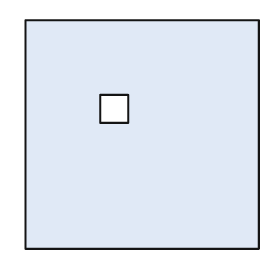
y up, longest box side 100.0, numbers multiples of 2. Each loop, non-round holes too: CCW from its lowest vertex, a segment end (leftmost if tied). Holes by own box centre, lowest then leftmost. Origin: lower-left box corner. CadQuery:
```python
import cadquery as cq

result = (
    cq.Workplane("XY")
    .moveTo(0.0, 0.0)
    .lineTo(100.0, 0.0)
    .lineTo(100.0, 98.0)
    .lineTo(0.0, 98.0)
    .close()
    .moveTo(32.0, 54.0)
    .lineTo(44.0, 54.0)
    .lineTo(44.0, 66.0)
    .lineTo(32.0, 66.0)
    .close()
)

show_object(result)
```